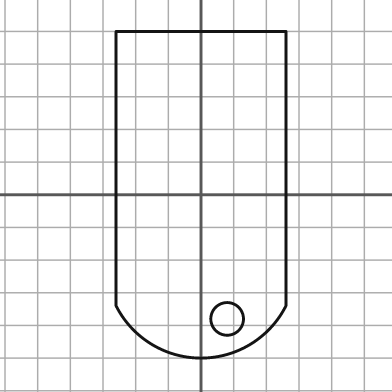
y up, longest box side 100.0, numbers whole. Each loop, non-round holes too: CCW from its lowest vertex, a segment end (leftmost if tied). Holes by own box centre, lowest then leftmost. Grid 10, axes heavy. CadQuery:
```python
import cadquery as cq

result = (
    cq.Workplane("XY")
    .moveTo(-26.0, -34.0)
    .threePointArc((0.0, -50.0), (26.0, -34.0))
    .lineTo(26.0, 50.0)
    .lineTo(-26.0, 50.0)
    .close()
    .moveTo(8.0, -38.0)
    .circle(5.0)
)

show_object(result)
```